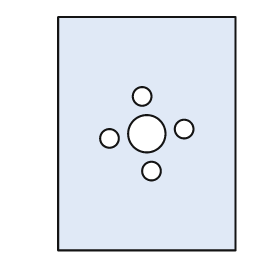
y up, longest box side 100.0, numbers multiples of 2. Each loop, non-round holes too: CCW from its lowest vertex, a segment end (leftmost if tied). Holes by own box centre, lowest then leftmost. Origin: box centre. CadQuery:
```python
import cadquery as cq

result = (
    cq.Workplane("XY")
    .moveTo(-38.0, -50.0)
    .lineTo(38.0, -50.0)
    .lineTo(38.0, 50.0)
    .lineTo(-38.0, 50.0)
    .close()
    .moveTo(2.0, -16.0)
    .circle(4.0)
    .moveTo(-16.0, -2.0)
    .circle(4.0)
    .moveTo(0.0, 0.0)
    .circle(8.0)
    .moveTo(16.0, 2.0)
    .circle(4.0)
    .moveTo(-2.0, 16.0)
    .circle(4.0)
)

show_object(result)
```